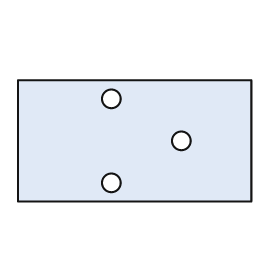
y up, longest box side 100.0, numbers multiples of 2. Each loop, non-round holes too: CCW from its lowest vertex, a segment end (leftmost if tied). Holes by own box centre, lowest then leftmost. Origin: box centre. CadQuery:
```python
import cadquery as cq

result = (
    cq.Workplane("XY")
    .moveTo(-50.0, -26.0)
    .lineTo(50.0, -26.0)
    .lineTo(50.0, 26.0)
    .lineTo(-50.0, 26.0)
    .close()
    .moveTo(-10.0, -18.0)
    .circle(4.0)
    .moveTo(20.0, 0.0)
    .circle(4.0)
    .moveTo(-10.0, 18.0)
    .circle(4.0)
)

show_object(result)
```